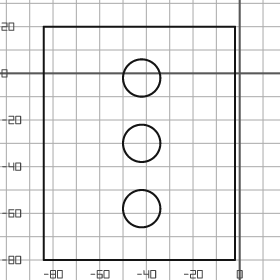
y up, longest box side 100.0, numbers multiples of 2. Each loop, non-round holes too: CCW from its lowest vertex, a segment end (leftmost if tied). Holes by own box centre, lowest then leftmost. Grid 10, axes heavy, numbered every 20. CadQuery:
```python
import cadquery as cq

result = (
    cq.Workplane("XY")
    .moveTo(-84.0, -80.0)
    .lineTo(-2.0, -80.0)
    .lineTo(-2.0, 20.0)
    .lineTo(-84.0, 20.0)
    .close()
    .moveTo(-42.0, -58.0)
    .circle(8.0)
    .moveTo(-42.0, -30.0)
    .circle(8.0)
    .moveTo(-42.0, -2.0)
    .circle(8.0)
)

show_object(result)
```